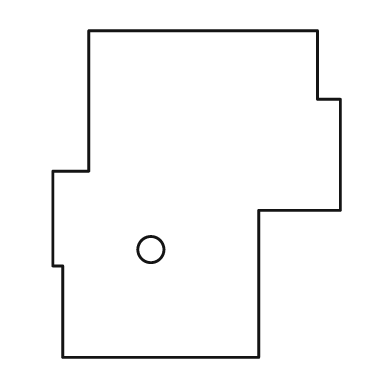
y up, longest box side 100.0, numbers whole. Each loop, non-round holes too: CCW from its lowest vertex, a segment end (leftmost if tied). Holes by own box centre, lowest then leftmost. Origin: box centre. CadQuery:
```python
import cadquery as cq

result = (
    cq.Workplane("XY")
    .moveTo(-41.0, -50.0)
    .lineTo(19.0, -50.0)
    .lineTo(19.0, -5.0)
    .lineTo(44.0, -5.0)
    .lineTo(44.0, 29.0)
    .lineTo(37.0, 29.0)
    .lineTo(37.0, 50.0)
    .lineTo(-33.0, 50.0)
    .lineTo(-33.0, 7.0)
    .lineTo(-44.0, 7.0)
    .lineTo(-44.0, -22.0)
    .lineTo(-41.0, -22.0)
    .close()
    .moveTo(-14.0, -17.0)
    .circle(4.0)
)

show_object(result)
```